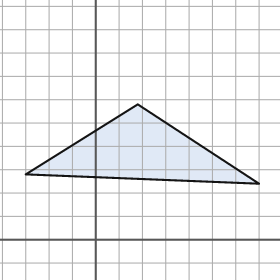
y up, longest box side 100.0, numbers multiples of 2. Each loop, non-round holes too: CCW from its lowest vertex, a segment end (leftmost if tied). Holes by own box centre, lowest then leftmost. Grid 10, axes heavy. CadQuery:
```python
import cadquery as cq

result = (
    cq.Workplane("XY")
    .moveTo(70.0, 24.0)
    .lineTo(18.0, 58.0)
    .lineTo(-30.0, 28.0)
    .close()
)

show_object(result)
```